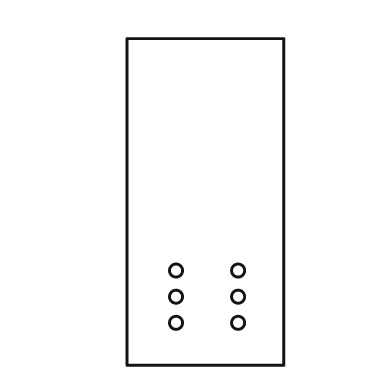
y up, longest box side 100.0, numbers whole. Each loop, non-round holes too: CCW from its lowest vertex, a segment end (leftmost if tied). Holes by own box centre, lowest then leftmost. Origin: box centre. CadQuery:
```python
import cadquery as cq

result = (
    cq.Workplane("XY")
    .moveTo(-24.0, -50.0)
    .lineTo(24.0, -50.0)
    .lineTo(24.0, 50.0)
    .lineTo(-24.0, 50.0)
    .close()
    .moveTo(-9.0, -37.0)
    .circle(2.0)
    .moveTo(10.0, -37.0)
    .circle(2.0)
    .moveTo(-9.0, -29.0)
    .circle(2.0)
    .moveTo(10.0, -29.0)
    .circle(2.0)
    .moveTo(-9.0, -21.0)
    .circle(2.0)
    .moveTo(10.0, -21.0)
    .circle(2.0)
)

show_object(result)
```